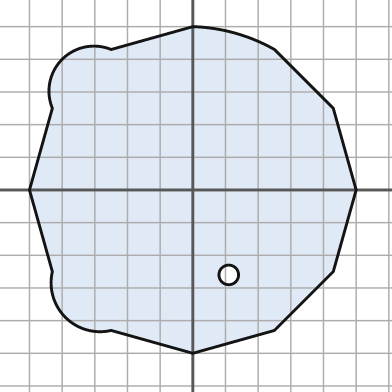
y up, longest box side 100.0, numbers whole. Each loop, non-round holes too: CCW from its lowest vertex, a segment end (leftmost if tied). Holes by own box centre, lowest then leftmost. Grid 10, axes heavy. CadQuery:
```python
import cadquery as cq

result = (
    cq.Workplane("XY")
    .moveTo(0.0, -50.0)
    .lineTo(25.0, -43.0)
    .lineTo(43.0, -25.0)
    .lineTo(50.0, 0.0)
    .lineTo(43.0, 25.0)
    .lineTo(25.0, 43.0)
    .threePointArc((13.0, 48.0), (0.0, 50.0))
    .lineTo(-25.0, 43.0)
    .threePointArc((-40.0, 40.0), (-43.0, 25.0))
    .lineTo(-50.0, 0.0)
    .lineTo(-43.0, -25.0)
    .threePointArc((-39.0, -39.0), (-25.0, -43.0))
    .close()
    .moveTo(11.0, -26.0)
    .circle(3.0)
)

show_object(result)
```